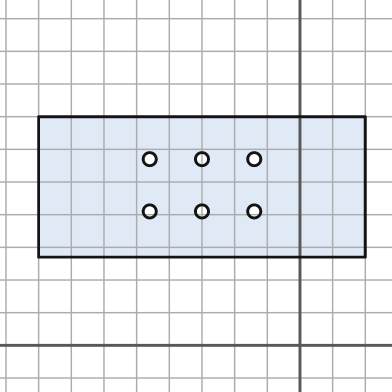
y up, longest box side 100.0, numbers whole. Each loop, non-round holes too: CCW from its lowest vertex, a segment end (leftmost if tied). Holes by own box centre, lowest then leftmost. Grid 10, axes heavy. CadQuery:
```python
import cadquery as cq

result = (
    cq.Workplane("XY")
    .moveTo(-80.0, 27.0)
    .lineTo(20.0, 27.0)
    .lineTo(20.0, 70.0)
    .lineTo(-80.0, 70.0)
    .close()
    .moveTo(-46.0, 41.0)
    .circle(2.0)
    .moveTo(-30.0, 41.0)
    .circle(2.0)
    .moveTo(-14.0, 41.0)
    .circle(2.0)
    .moveTo(-46.0, 57.0)
    .circle(2.0)
    .moveTo(-30.0, 57.0)
    .circle(2.0)
    .moveTo(-14.0, 57.0)
    .circle(2.0)
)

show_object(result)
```